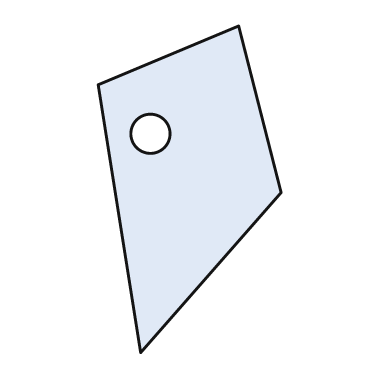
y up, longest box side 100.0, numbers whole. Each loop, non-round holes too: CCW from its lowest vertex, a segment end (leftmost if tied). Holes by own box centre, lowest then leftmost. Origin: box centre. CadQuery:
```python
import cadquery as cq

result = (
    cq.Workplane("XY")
    .moveTo(-15.0, -50.0)
    .lineTo(28.0, -1.0)
    .lineTo(15.0, 50.0)
    .lineTo(-28.0, 32.0)
    .close()
    .moveTo(-12.0, 17.0)
    .circle(6.0)
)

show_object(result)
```